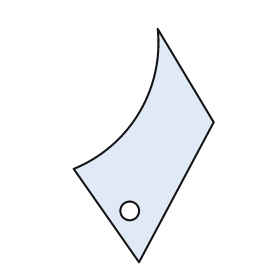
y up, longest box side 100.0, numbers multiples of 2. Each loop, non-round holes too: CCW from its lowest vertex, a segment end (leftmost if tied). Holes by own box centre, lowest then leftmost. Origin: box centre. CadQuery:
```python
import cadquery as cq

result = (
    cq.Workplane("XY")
    .moveTo(-2.0, -50.0)
    .lineTo(30.0, 10.0)
    .lineTo(6.0, 50.0)
    .threePointArc((-2.0, 14.0), (-30.0, -10.0))
    .close()
    .moveTo(-6.0, -28.0)
    .circle(4.0)
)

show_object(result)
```